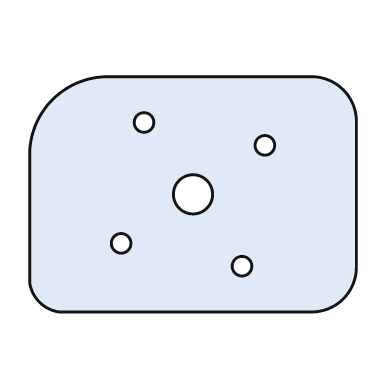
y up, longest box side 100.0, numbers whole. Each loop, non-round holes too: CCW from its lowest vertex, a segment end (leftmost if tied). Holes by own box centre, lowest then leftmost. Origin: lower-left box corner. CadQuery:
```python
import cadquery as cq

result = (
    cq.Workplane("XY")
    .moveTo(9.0, 0.0)
    .lineTo(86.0, 0.0)
    .threePointArc((96.0, 4.0), (100.0, 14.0))
    .lineTo(100.0, 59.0)
    .threePointArc((96.0, 68.0), (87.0, 72.0))
    .lineTo(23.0, 72.0)
    .threePointArc((7.0, 65.0), (0.0, 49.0))
    .lineTo(0.0, 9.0)
    .threePointArc((3.0, 3.0), (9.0, 0.0))
    .close()
    .moveTo(65.0, 14.0)
    .circle(3.0)
    .moveTo(28.0, 21.0)
    .circle(3.0)
    .moveTo(50.0, 36.0)
    .circle(6.0)
    .moveTo(72.0, 51.0)
    .circle(3.0)
    .moveTo(35.0, 58.0)
    .circle(3.0)
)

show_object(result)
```